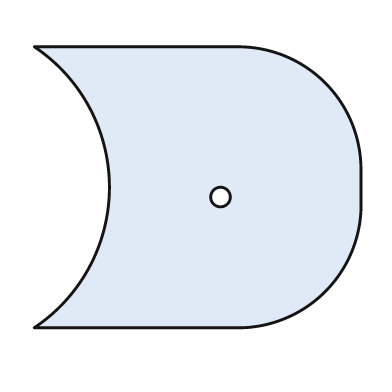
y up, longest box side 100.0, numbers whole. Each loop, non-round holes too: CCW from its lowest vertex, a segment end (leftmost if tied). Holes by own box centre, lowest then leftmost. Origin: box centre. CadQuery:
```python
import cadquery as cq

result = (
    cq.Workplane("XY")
    .moveTo(-50.0, -43.0)
    .lineTo(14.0, -43.0)
    .threePointArc((39.0, -32.0), (50.0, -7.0))
    .lineTo(50.0, 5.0)
    .threePointArc((39.0, 32.0), (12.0, 43.0))
    .lineTo(-50.0, 43.0)
    .threePointArc((-27.0, 0.0), (-50.0, -43.0))
    .close()
    .moveTo(7.0, -3.0)
    .circle(3.0)
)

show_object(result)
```